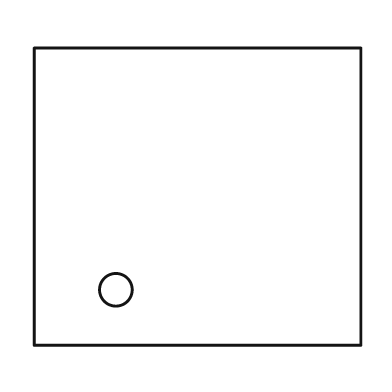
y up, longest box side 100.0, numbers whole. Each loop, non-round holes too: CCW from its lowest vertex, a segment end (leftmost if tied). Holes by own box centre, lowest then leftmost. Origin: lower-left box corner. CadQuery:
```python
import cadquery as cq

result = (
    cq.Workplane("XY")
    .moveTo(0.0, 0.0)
    .lineTo(100.0, 0.0)
    .lineTo(100.0, 91.0)
    .lineTo(0.0, 91.0)
    .close()
    .moveTo(25.0, 17.0)
    .circle(5.0)
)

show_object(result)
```